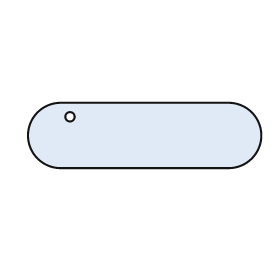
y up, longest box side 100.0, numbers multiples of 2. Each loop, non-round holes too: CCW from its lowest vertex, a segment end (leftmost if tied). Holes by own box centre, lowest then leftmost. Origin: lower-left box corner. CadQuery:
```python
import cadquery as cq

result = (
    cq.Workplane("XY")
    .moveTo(14.0, 0.0)
    .lineTo(86.0, 0.0)
    .threePointArc((100.0, 14.0), (86.0, 28.0))
    .lineTo(14.0, 28.0)
    .threePointArc((0.0, 14.0), (14.0, 0.0))
    .close()
    .moveTo(18.0, 22.0)
    .circle(2.0)
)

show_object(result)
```